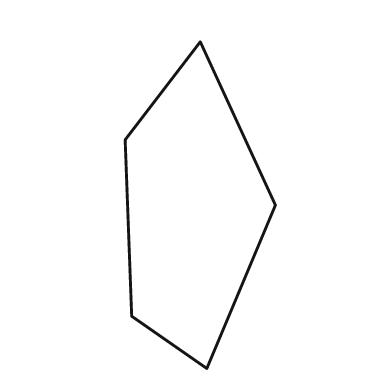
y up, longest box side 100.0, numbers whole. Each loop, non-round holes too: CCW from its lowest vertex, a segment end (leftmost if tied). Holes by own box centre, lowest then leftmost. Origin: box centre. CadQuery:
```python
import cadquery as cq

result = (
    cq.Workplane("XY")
    .moveTo(2.0, -50.0)
    .lineTo(23.0, 0.0)
    .lineTo(0.0, 50.0)
    .lineTo(-23.0, 20.0)
    .lineTo(-21.0, -34.0)
    .close()
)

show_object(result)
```